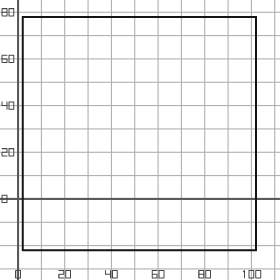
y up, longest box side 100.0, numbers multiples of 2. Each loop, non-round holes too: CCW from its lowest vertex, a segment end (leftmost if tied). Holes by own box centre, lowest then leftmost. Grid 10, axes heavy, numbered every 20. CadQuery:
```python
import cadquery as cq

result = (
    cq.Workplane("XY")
    .moveTo(2.0, -22.0)
    .lineTo(102.0, -22.0)
    .lineTo(102.0, 78.0)
    .lineTo(2.0, 78.0)
    .close()
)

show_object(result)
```